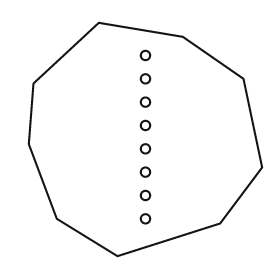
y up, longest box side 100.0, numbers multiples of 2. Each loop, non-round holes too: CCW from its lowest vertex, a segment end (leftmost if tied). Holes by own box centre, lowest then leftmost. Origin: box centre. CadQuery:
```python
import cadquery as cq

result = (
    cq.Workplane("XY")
    .moveTo(-12.0, -50.0)
    .lineTo(32.0, -36.0)
    .lineTo(50.0, -12.0)
    .lineTo(42.0, 26.0)
    .lineTo(16.0, 44.0)
    .lineTo(-20.0, 50.0)
    .lineTo(-48.0, 24.0)
    .lineTo(-50.0, -2.0)
    .lineTo(-38.0, -34.0)
    .close()
    .moveTo(0.0, -34.0)
    .circle(2.0)
    .moveTo(0.0, -24.0)
    .circle(2.0)
    .moveTo(0.0, -14.0)
    .circle(2.0)
    .moveTo(0.0, -4.0)
    .circle(2.0)
    .moveTo(0.0, 6.0)
    .circle(2.0)
    .moveTo(0.0, 16.0)
    .circle(2.0)
    .moveTo(0.0, 26.0)
    .circle(2.0)
    .moveTo(0.0, 36.0)
    .circle(2.0)
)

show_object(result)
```